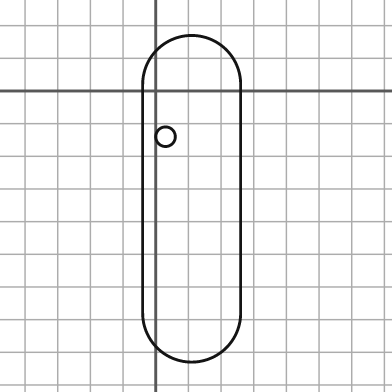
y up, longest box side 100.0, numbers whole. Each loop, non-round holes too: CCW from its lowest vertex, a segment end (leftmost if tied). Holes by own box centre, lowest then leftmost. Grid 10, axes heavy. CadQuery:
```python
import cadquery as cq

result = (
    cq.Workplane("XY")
    .moveTo(-4.0, -68.0)
    .threePointArc((11.0, -83.0), (26.0, -68.0))
    .lineTo(26.0, 2.0)
    .threePointArc((11.0, 17.0), (-4.0, 2.0))
    .close()
    .moveTo(3.0, -14.0)
    .circle(3.0)
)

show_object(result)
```